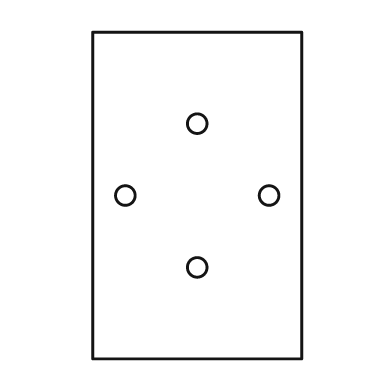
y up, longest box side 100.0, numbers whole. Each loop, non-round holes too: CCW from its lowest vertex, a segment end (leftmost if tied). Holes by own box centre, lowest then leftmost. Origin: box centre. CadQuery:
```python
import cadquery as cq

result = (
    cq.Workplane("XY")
    .moveTo(-32.0, -50.0)
    .lineTo(32.0, -50.0)
    .lineTo(32.0, 50.0)
    .lineTo(-32.0, 50.0)
    .close()
    .moveTo(0.0, -22.0)
    .circle(3.0)
    .moveTo(-22.0, 0.0)
    .circle(3.0)
    .moveTo(22.0, 0.0)
    .circle(3.0)
    .moveTo(0.0, 22.0)
    .circle(3.0)
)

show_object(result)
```